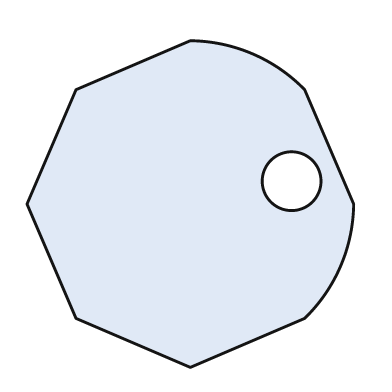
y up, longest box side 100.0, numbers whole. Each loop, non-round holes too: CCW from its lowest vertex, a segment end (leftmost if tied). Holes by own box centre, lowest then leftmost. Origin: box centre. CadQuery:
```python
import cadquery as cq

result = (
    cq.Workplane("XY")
    .moveTo(0.0, -50.0)
    .lineTo(35.0, -35.0)
    .threePointArc((46.0, -19.0), (50.0, 0.0))
    .lineTo(35.0, 35.0)
    .threePointArc((19.0, 46.0), (0.0, 50.0))
    .lineTo(-35.0, 35.0)
    .lineTo(-50.0, 0.0)
    .lineTo(-35.0, -35.0)
    .close()
    .moveTo(31.0, 7.0)
    .circle(9.0)
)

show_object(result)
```